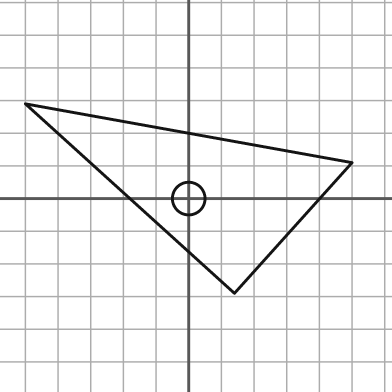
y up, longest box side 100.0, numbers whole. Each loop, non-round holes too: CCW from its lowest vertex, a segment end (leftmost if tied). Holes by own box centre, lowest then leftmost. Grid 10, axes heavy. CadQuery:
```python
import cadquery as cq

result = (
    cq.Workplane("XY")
    .moveTo(14.0, -29.0)
    .lineTo(50.0, 11.0)
    .lineTo(-50.0, 29.0)
    .close()
    .moveTo(0.0, 0.0)
    .circle(5.0)
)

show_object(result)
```